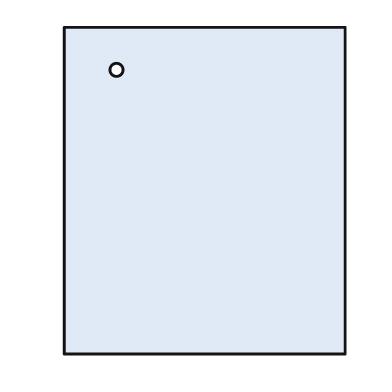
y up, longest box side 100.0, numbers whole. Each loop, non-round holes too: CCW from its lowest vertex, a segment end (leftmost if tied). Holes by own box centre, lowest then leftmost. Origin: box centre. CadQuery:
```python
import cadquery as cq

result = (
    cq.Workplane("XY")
    .moveTo(-43.0, -50.0)
    .lineTo(43.0, -50.0)
    .lineTo(43.0, 50.0)
    .lineTo(-43.0, 50.0)
    .close()
    .moveTo(-27.0, 37.0)
    .circle(2.0)
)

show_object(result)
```